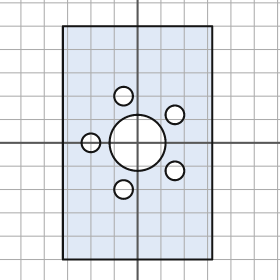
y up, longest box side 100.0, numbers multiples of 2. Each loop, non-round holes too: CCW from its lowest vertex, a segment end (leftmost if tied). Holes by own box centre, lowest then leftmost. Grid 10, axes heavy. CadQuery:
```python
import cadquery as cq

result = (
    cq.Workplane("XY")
    .moveTo(-32.0, -50.0)
    .lineTo(32.0, -50.0)
    .lineTo(32.0, 50.0)
    .lineTo(-32.0, 50.0)
    .close()
    .moveTo(-6.0, -20.0)
    .circle(4.0)
    .moveTo(16.0, -12.0)
    .circle(4.0)
    .moveTo(-20.0, 0.0)
    .circle(4.0)
    .moveTo(0.0, 0.0)
    .circle(12.0)
    .moveTo(16.0, 12.0)
    .circle(4.0)
    .moveTo(-6.0, 20.0)
    .circle(4.0)
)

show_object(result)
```